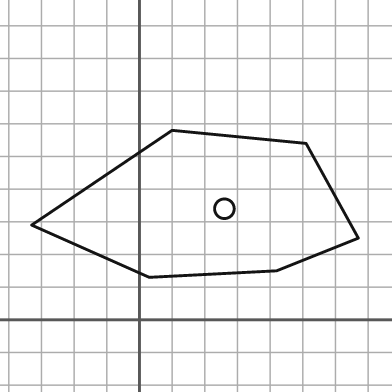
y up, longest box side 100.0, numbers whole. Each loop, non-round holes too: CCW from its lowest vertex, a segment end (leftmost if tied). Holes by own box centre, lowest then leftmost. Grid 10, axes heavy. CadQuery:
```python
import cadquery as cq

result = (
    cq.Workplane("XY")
    .moveTo(3.0, 13.0)
    .lineTo(42.0, 15.0)
    .lineTo(67.0, 25.0)
    .lineTo(51.0, 54.0)
    .lineTo(10.0, 58.0)
    .lineTo(-33.0, 29.0)
    .close()
    .moveTo(26.0, 34.0)
    .circle(3.0)
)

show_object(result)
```